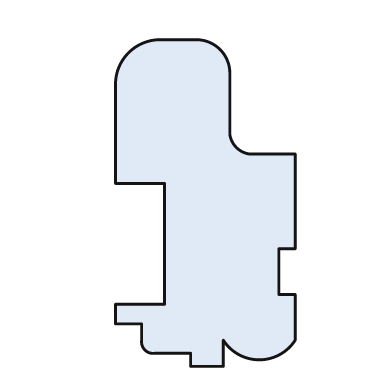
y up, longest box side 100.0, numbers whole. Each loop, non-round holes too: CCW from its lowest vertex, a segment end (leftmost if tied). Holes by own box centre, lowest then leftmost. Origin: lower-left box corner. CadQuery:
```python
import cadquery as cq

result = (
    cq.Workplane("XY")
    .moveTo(23.0, 0.0)
    .lineTo(33.0, 0.0)
    .lineTo(33.0, 8.0)
    .threePointArc((44.0, 2.0), (55.0, 8.0))
    .lineTo(55.0, 22.0)
    .lineTo(50.0, 22.0)
    .lineTo(50.0, 36.0)
    .lineTo(55.0, 36.0)
    .lineTo(55.0, 65.0)
    .lineTo(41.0, 65.0)
    .threePointArc((37.0, 67.0), (35.0, 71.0))
    .lineTo(35.0, 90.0)
    .threePointArc((32.0, 97.0), (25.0, 100.0))
    .lineTo(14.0, 100.0)
    .threePointArc((4.0, 96.0), (0.0, 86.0))
    .lineTo(0.0, 56.0)
    .lineTo(15.0, 56.0)
    .lineTo(15.0, 19.0)
    .lineTo(0.0, 19.0)
    .lineTo(0.0, 13.0)
    .lineTo(8.0, 13.0)
    .lineTo(8.0, 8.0)
    .threePointArc((9.0, 5.0), (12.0, 4.0))
    .lineTo(23.0, 4.0)
    .close()
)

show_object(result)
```